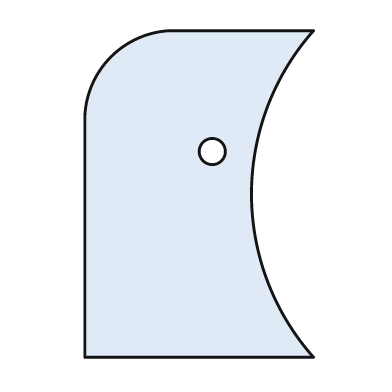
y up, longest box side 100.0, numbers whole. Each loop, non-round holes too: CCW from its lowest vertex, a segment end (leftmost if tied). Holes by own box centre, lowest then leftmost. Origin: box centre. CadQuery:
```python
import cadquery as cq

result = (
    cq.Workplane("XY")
    .moveTo(-35.0, -50.0)
    .lineTo(35.0, -50.0)
    .threePointArc((16.0, 0.0), (35.0, 50.0))
    .lineTo(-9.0, 50.0)
    .threePointArc((-27.0, 42.0), (-35.0, 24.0))
    .close()
    .moveTo(4.0, 13.0)
    .circle(4.0)
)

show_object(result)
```